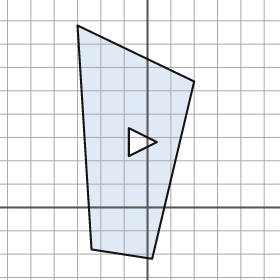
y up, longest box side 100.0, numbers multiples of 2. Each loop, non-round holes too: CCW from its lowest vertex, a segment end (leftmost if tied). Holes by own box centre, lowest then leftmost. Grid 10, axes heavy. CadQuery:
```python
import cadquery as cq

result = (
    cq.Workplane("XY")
    .moveTo(2.0, -22.0)
    .lineTo(20.0, 54.0)
    .lineTo(-30.0, 78.0)
    .lineTo(-24.0, -18.0)
    .close()
    .moveTo(-8.0, 22.0)
    .lineTo(4.0, 28.0)
    .lineTo(-8.0, 34.0)
    .close()
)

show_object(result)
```